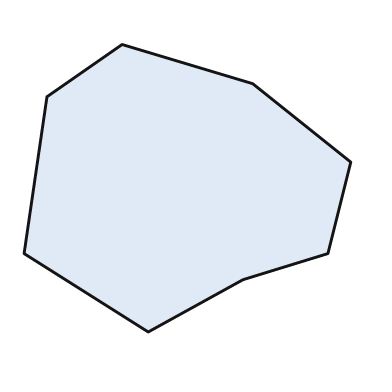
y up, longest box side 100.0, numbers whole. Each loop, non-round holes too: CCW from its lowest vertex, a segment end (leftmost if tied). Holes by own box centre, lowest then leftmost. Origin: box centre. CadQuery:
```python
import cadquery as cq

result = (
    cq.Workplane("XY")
    .moveTo(-12.0, -44.0)
    .lineTo(17.0, -28.0)
    .lineTo(43.0, -20.0)
    .lineTo(50.0, 8.0)
    .lineTo(20.0, 32.0)
    .lineTo(-20.0, 44.0)
    .lineTo(-43.0, 28.0)
    .lineTo(-50.0, -20.0)
    .close()
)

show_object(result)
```